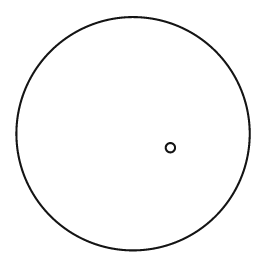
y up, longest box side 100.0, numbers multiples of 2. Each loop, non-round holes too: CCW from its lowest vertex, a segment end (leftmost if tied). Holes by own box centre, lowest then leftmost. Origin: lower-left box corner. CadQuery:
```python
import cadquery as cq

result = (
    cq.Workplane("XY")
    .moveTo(50.0, 50.0)
    .circle(50.0)
    .moveTo(66.0, 44.0)
    .circle(2.0)
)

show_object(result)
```